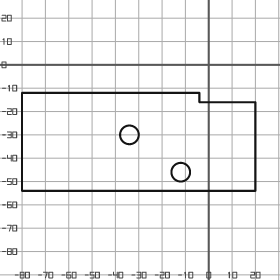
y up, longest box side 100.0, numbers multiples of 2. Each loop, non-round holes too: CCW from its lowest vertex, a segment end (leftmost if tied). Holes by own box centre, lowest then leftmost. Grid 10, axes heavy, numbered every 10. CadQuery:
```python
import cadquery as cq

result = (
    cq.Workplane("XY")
    .moveTo(-80.0, -54.0)
    .lineTo(20.0, -54.0)
    .lineTo(20.0, -16.0)
    .lineTo(-4.0, -16.0)
    .lineTo(-4.0, -12.0)
    .lineTo(-80.0, -12.0)
    .close()
    .moveTo(-12.0, -46.0)
    .circle(4.0)
    .moveTo(-34.0, -30.0)
    .circle(4.0)
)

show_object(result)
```